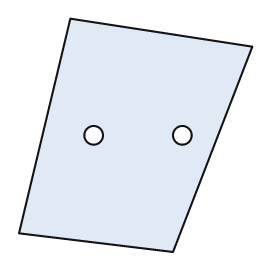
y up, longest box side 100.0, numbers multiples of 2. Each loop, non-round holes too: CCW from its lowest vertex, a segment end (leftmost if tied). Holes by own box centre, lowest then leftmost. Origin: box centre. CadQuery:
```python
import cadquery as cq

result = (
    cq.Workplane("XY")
    .moveTo(16.0, -50.0)
    .lineTo(50.0, 38.0)
    .lineTo(-28.0, 50.0)
    .lineTo(-50.0, -42.0)
    .close()
    .moveTo(-18.0, 0.0)
    .circle(4.0)
    .moveTo(20.0, 0.0)
    .circle(4.0)
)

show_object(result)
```